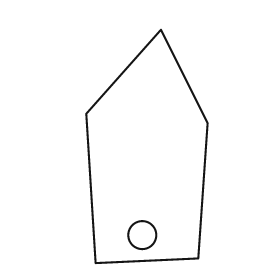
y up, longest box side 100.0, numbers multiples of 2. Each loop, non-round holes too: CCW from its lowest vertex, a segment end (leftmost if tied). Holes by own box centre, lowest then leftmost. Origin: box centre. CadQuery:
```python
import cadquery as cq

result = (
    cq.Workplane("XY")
    .moveTo(-22.0, -50.0)
    .lineTo(22.0, -48.0)
    .lineTo(26.0, 10.0)
    .lineTo(6.0, 50.0)
    .lineTo(-26.0, 14.0)
    .close()
    .moveTo(-2.0, -38.0)
    .circle(6.0)
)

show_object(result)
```